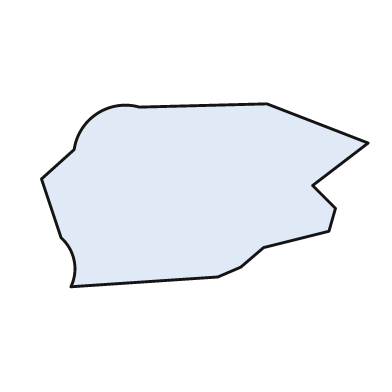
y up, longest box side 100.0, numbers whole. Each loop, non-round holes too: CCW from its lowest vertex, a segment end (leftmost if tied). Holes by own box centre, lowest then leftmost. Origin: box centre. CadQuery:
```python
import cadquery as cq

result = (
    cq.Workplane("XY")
    .moveTo(-41.0, -28.0)
    .lineTo(4.0, -25.0)
    .lineTo(11.0, -22.0)
    .lineTo(18.0, -16.0)
    .lineTo(38.0, -11.0)
    .lineTo(40.0, -4.0)
    .lineTo(33.0, 3.0)
    .lineTo(50.0, 16.0)
    .lineTo(19.0, 28.0)
    .lineTo(-20.0, 27.0)
    .threePointArc((-33.0, 25.0), (-40.0, 14.0))
    .lineTo(-50.0, 5.0)
    .lineTo(-44.0, -13.0)
    .threePointArc((-40.0, -20.0), (-41.0, -28.0))
    .close()
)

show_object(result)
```